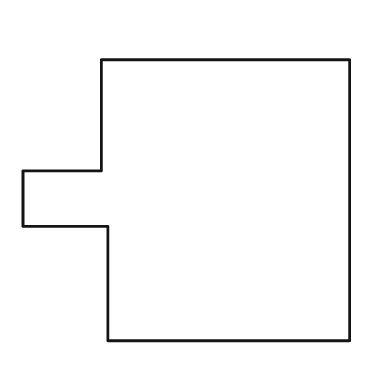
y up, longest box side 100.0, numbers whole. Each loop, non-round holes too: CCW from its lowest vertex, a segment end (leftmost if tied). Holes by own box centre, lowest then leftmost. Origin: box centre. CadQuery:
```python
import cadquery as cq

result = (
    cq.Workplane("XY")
    .moveTo(-24.0, -43.0)
    .lineTo(50.0, -43.0)
    .lineTo(50.0, 43.0)
    .lineTo(-26.0, 43.0)
    .lineTo(-26.0, 9.0)
    .lineTo(-50.0, 9.0)
    .lineTo(-50.0, -8.0)
    .lineTo(-24.0, -8.0)
    .close()
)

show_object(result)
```